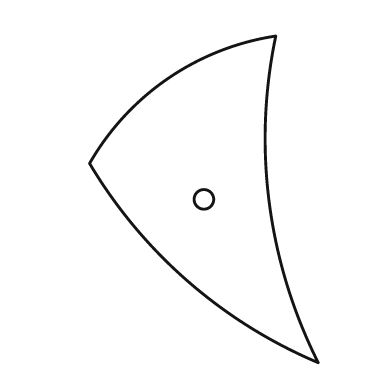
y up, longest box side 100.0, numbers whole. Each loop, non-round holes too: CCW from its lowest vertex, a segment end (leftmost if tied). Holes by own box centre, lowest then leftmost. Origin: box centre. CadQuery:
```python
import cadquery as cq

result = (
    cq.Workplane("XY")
    .moveTo(35.0, -50.0)
    .threePointArc((20.0, -1.0), (22.0, 50.0))
    .threePointArc((-11.0, 37.0), (-35.0, 11.0))
    .threePointArc((-5.0, -25.0), (35.0, -50.0))
    .close()
    .moveTo(0.0, 0.0)
    .circle(3.0)
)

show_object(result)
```